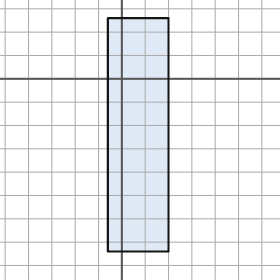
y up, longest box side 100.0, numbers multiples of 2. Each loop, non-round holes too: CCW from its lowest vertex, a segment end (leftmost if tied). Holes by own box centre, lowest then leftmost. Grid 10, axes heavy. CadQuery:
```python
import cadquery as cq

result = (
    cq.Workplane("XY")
    .moveTo(-6.0, -74.0)
    .lineTo(20.0, -74.0)
    .lineTo(20.0, 26.0)
    .lineTo(-6.0, 26.0)
    .close()
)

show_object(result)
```